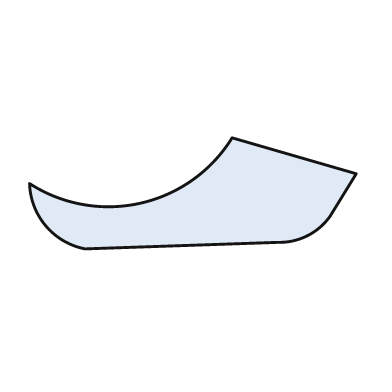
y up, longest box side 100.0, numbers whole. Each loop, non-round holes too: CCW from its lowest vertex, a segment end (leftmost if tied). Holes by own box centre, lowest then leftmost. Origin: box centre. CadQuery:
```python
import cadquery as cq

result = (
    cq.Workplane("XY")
    .moveTo(-33.0, -17.0)
    .lineTo(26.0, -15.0)
    .threePointArc((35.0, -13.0), (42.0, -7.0))
    .lineTo(50.0, 6.0)
    .lineTo(12.0, 17.0)
    .threePointArc((-16.0, -3.0), (-50.0, 3.0))
    .threePointArc((-45.0, -10.0), (-33.0, -17.0))
    .close()
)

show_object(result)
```